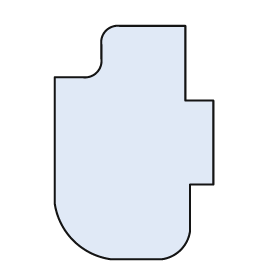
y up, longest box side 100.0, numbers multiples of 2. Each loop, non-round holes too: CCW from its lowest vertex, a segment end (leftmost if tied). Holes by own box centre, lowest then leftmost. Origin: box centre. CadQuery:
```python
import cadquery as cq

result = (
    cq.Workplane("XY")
    .moveTo(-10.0, -50.0)
    .lineTo(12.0, -50.0)
    .threePointArc((20.0, -46.0), (24.0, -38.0))
    .lineTo(24.0, -18.0)
    .lineTo(34.0, -18.0)
    .lineTo(34.0, 18.0)
    .lineTo(22.0, 18.0)
    .lineTo(22.0, 50.0)
    .lineTo(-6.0, 50.0)
    .threePointArc((-12.0, 48.0), (-14.0, 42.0))
    .lineTo(-14.0, 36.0)
    .threePointArc((-16.0, 30.0), (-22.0, 28.0))
    .lineTo(-34.0, 28.0)
    .lineTo(-34.0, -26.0)
    .threePointArc((-26.0, -42.0), (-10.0, -50.0))
    .close()
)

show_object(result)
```